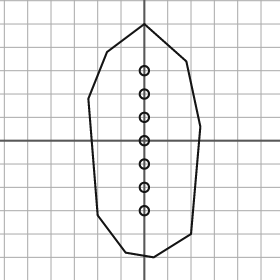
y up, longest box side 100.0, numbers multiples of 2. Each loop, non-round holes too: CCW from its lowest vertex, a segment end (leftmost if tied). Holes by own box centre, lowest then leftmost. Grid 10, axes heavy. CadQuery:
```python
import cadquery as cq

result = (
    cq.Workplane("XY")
    .moveTo(4.0, -50.0)
    .lineTo(20.0, -40.0)
    .lineTo(24.0, 6.0)
    .lineTo(18.0, 34.0)
    .lineTo(0.0, 50.0)
    .lineTo(-16.0, 38.0)
    .lineTo(-24.0, 18.0)
    .lineTo(-20.0, -32.0)
    .lineTo(-8.0, -48.0)
    .close()
    .moveTo(0.0, -30.0)
    .circle(2.0)
    .moveTo(0.0, -20.0)
    .circle(2.0)
    .moveTo(0.0, -10.0)
    .circle(2.0)
    .moveTo(0.0, 0.0)
    .circle(2.0)
    .moveTo(0.0, 10.0)
    .circle(2.0)
    .moveTo(0.0, 20.0)
    .circle(2.0)
    .moveTo(0.0, 30.0)
    .circle(2.0)
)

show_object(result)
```